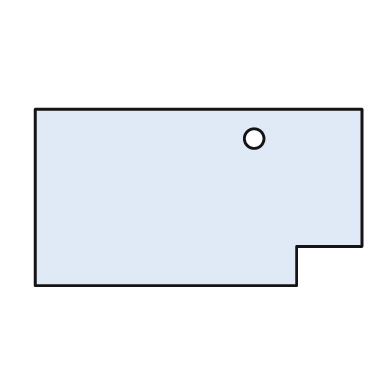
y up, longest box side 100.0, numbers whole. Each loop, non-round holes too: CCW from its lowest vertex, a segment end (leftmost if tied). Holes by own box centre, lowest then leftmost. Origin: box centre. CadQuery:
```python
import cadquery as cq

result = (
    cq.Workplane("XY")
    .moveTo(-50.0, -27.0)
    .lineTo(30.0, -27.0)
    .lineTo(30.0, -15.0)
    .lineTo(50.0, -15.0)
    .lineTo(50.0, 27.0)
    .lineTo(-50.0, 27.0)
    .close()
    .moveTo(17.0, 18.0)
    .circle(3.0)
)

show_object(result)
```